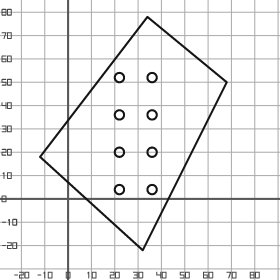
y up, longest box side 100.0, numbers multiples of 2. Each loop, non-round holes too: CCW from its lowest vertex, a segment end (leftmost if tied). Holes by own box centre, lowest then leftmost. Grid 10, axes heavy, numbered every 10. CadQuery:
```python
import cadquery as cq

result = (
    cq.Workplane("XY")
    .moveTo(32.0, -22.0)
    .lineTo(68.0, 50.0)
    .lineTo(34.0, 78.0)
    .lineTo(-12.0, 18.0)
    .close()
    .moveTo(22.0, 4.0)
    .circle(2.0)
    .moveTo(36.0, 4.0)
    .circle(2.0)
    .moveTo(22.0, 20.0)
    .circle(2.0)
    .moveTo(36.0, 20.0)
    .circle(2.0)
    .moveTo(22.0, 36.0)
    .circle(2.0)
    .moveTo(36.0, 36.0)
    .circle(2.0)
    .moveTo(22.0, 52.0)
    .circle(2.0)
    .moveTo(36.0, 52.0)
    .circle(2.0)
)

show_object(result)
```